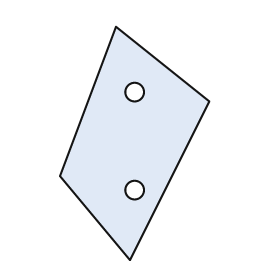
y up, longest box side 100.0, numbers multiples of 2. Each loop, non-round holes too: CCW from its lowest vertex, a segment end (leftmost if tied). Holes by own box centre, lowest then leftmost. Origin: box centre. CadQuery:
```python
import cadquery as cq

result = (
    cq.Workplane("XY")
    .moveTo(-2.0, -50.0)
    .lineTo(32.0, 18.0)
    .lineTo(-8.0, 50.0)
    .lineTo(-32.0, -14.0)
    .close()
    .moveTo(0.0, -20.0)
    .circle(4.0)
    .moveTo(0.0, 22.0)
    .circle(4.0)
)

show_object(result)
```